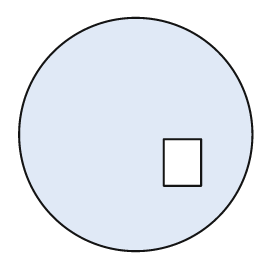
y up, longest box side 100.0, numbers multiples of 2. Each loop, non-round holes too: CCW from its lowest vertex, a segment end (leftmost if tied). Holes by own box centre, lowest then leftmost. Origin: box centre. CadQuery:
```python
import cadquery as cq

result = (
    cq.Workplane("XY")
    .moveTo(0.0, 0.0)
    .circle(50.0)
    .moveTo(12.0, -22.0)
    .lineTo(28.0, -22.0)
    .lineTo(28.0, -2.0)
    .lineTo(12.0, -2.0)
    .close()
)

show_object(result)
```